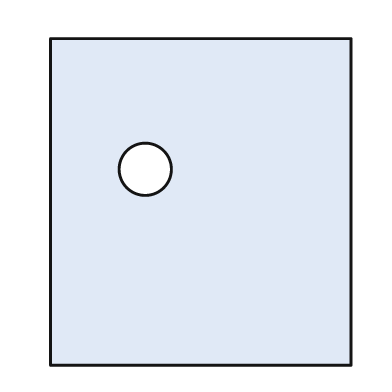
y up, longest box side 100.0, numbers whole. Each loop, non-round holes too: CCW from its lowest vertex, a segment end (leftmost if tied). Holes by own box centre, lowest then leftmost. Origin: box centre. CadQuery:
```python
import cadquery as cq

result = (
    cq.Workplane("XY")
    .moveTo(-46.0, -50.0)
    .lineTo(46.0, -50.0)
    .lineTo(46.0, 50.0)
    .lineTo(-46.0, 50.0)
    .close()
    .moveTo(-17.0, 10.0)
    .circle(8.0)
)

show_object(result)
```